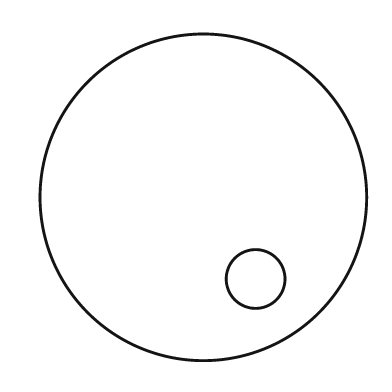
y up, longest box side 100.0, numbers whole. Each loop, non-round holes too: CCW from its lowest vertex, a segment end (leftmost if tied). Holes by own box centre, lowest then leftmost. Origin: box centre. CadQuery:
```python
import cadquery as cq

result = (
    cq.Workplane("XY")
    .moveTo(0.0, 0.0)
    .circle(50.0)
    .moveTo(16.0, -25.0)
    .circle(9.0)
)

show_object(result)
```